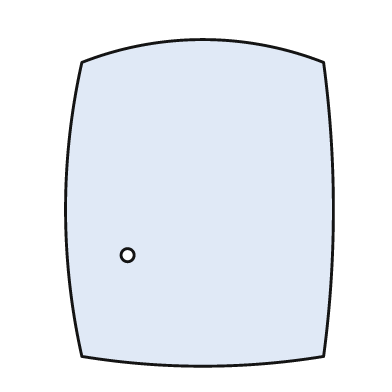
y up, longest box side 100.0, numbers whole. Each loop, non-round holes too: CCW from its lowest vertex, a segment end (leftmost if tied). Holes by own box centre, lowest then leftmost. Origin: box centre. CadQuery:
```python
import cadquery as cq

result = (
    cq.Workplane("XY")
    .moveTo(-36.0, -47.0)
    .threePointArc((1.0, -50.0), (38.0, -47.0))
    .threePointArc((41.0, -2.0), (38.0, 43.0))
    .threePointArc((1.0, 50.0), (-36.0, 43.0))
    .threePointArc((-41.0, -2.0), (-36.0, -47.0))
    .close()
    .moveTo(-22.0, -16.0)
    .circle(2.0)
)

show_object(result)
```